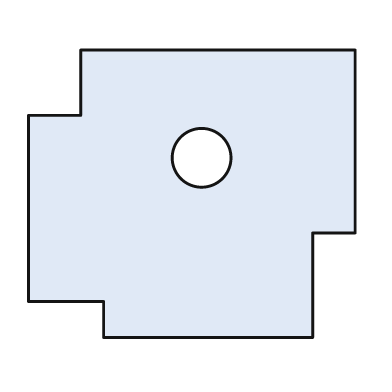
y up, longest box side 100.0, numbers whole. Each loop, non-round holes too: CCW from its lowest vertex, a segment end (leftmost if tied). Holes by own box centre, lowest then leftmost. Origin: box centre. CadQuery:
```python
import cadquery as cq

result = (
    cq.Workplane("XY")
    .moveTo(-27.0, -44.0)
    .lineTo(37.0, -44.0)
    .lineTo(37.0, -12.0)
    .lineTo(50.0, -12.0)
    .lineTo(50.0, 44.0)
    .lineTo(-34.0, 44.0)
    .lineTo(-34.0, 24.0)
    .lineTo(-50.0, 24.0)
    .lineTo(-50.0, -33.0)
    .lineTo(-27.0, -33.0)
    .close()
    .moveTo(3.0, 11.0)
    .circle(9.0)
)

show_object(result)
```